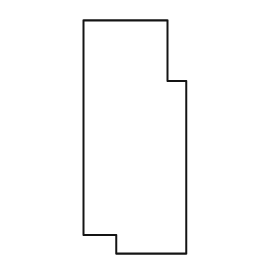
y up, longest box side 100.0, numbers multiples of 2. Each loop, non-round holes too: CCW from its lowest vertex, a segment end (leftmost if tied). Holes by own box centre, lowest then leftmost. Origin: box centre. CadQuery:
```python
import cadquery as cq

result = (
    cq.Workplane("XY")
    .moveTo(-8.0, -50.0)
    .lineTo(22.0, -50.0)
    .lineTo(22.0, 24.0)
    .lineTo(14.0, 24.0)
    .lineTo(14.0, 50.0)
    .lineTo(-22.0, 50.0)
    .lineTo(-22.0, -42.0)
    .lineTo(-8.0, -42.0)
    .close()
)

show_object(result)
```